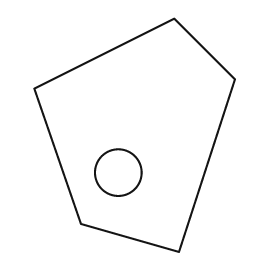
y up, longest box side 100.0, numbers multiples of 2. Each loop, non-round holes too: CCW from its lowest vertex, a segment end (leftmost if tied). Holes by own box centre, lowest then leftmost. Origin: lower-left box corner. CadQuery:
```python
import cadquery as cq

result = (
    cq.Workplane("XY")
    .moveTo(62.0, 0.0)
    .lineTo(86.0, 74.0)
    .lineTo(60.0, 100.0)
    .lineTo(0.0, 70.0)
    .lineTo(20.0, 12.0)
    .close()
    .moveTo(36.0, 34.0)
    .circle(10.0)
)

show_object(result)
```